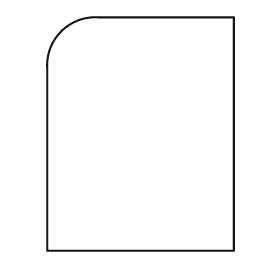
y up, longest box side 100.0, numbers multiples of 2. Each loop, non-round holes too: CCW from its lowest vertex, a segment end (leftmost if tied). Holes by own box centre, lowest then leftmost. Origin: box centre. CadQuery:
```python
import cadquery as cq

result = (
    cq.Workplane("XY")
    .moveTo(-40.0, -50.0)
    .lineTo(40.0, -50.0)
    .lineTo(40.0, 50.0)
    .lineTo(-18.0, 50.0)
    .threePointArc((-34.0, 44.0), (-40.0, 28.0))
    .close()
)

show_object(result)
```